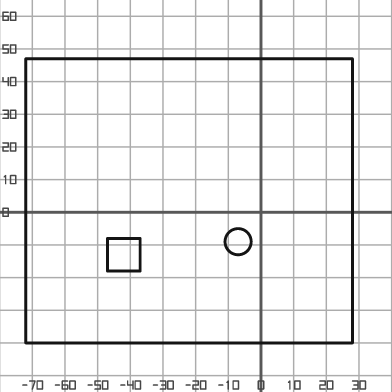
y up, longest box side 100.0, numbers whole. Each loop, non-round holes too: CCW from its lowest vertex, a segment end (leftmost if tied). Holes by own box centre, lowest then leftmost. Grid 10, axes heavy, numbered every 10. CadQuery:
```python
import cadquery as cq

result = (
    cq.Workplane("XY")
    .moveTo(-72.0, -40.0)
    .lineTo(28.0, -40.0)
    .lineTo(28.0, 47.0)
    .lineTo(-72.0, 47.0)
    .close()
    .moveTo(-47.0, -18.0)
    .lineTo(-37.0, -18.0)
    .lineTo(-37.0, -8.0)
    .lineTo(-47.0, -8.0)
    .close()
    .moveTo(-7.0, -9.0)
    .circle(4.0)
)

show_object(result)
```